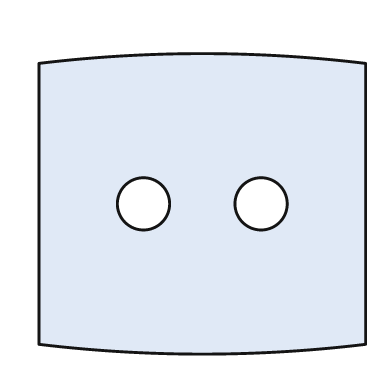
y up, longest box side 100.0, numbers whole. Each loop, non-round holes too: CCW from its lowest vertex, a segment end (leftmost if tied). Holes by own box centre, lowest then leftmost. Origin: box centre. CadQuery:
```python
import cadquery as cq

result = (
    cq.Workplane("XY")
    .moveTo(-50.0, -43.0)
    .threePointArc((0.0, -46.0), (50.0, -43.0))
    .lineTo(50.0, 43.0)
    .threePointArc((0.0, 46.0), (-50.0, 43.0))
    .close()
    .moveTo(-18.0, 0.0)
    .circle(8.0)
    .moveTo(18.0, 0.0)
    .circle(8.0)
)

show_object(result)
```